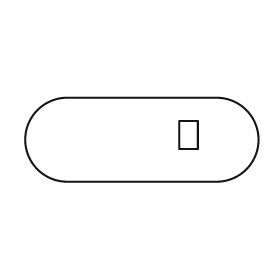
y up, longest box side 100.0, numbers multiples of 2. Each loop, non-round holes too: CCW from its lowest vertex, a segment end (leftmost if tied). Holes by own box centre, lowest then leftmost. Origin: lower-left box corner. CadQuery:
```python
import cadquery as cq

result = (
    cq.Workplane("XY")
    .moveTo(18.0, 0.0)
    .lineTo(82.0, 0.0)
    .threePointArc((100.0, 18.0), (82.0, 36.0))
    .lineTo(18.0, 36.0)
    .threePointArc((0.0, 18.0), (18.0, 0.0))
    .close()
    .moveTo(66.0, 14.0)
    .lineTo(74.0, 14.0)
    .lineTo(74.0, 26.0)
    .lineTo(66.0, 26.0)
    .close()
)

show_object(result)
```